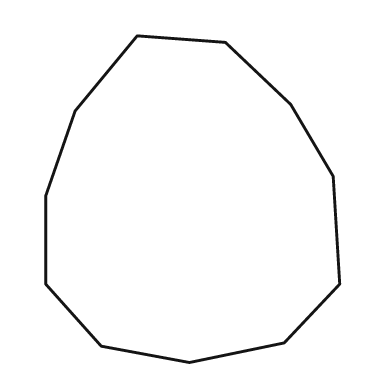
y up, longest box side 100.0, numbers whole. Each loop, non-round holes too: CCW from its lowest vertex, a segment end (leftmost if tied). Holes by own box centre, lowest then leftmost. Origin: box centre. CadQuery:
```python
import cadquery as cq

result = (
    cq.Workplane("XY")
    .moveTo(-1.0, -50.0)
    .lineTo(28.0, -44.0)
    .lineTo(45.0, -26.0)
    .lineTo(43.0, 7.0)
    .lineTo(30.0, 29.0)
    .lineTo(10.0, 48.0)
    .lineTo(-17.0, 50.0)
    .lineTo(-36.0, 27.0)
    .lineTo(-45.0, 1.0)
    .lineTo(-45.0, -26.0)
    .lineTo(-28.0, -45.0)
    .close()
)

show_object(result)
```